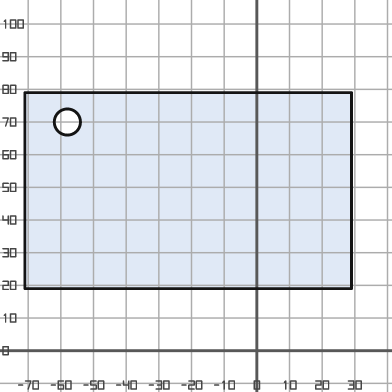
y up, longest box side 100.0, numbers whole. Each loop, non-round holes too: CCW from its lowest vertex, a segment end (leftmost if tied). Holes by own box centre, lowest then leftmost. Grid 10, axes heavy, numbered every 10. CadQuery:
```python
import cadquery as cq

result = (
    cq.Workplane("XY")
    .moveTo(-71.0, 19.0)
    .lineTo(29.0, 19.0)
    .lineTo(29.0, 79.0)
    .lineTo(-71.0, 79.0)
    .close()
    .moveTo(-58.0, 70.0)
    .circle(4.0)
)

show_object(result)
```